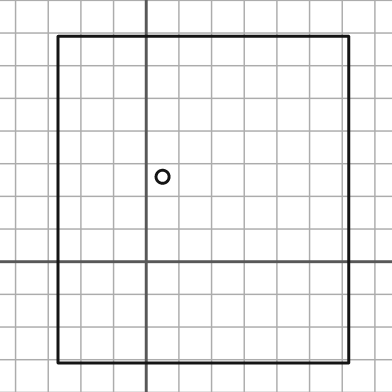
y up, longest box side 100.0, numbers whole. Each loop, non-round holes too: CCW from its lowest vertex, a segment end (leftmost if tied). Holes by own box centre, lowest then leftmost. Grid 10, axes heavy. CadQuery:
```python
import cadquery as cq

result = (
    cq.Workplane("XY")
    .moveTo(-27.0, -31.0)
    .lineTo(62.0, -31.0)
    .lineTo(62.0, 69.0)
    .lineTo(-27.0, 69.0)
    .close()
    .moveTo(5.0, 26.0)
    .circle(2.0)
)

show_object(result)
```